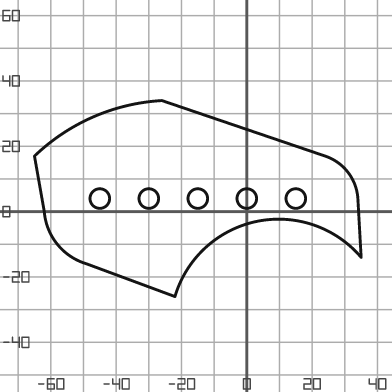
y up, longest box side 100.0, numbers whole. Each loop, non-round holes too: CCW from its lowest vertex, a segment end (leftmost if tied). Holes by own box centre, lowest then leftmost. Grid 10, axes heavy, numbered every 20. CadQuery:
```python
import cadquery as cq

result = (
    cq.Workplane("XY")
    .moveTo(-22.0, -26.0)
    .threePointArc((3.0, -3.0), (35.0, -14.0))
    .lineTo(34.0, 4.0)
    .threePointArc((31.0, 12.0), (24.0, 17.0))
    .lineTo(-26.0, 34.0)
    .threePointArc((-47.0, 29.0), (-65.0, 17.0))
    .lineTo(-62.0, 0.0)
    .threePointArc((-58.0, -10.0), (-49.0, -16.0))
    .close()
    .moveTo(-45.0, 4.0)
    .circle(3.0)
    .moveTo(-30.0, 4.0)
    .circle(3.0)
    .moveTo(-15.0, 4.0)
    .circle(3.0)
    .moveTo(0.0, 4.0)
    .circle(3.0)
    .moveTo(15.0, 4.0)
    .circle(3.0)
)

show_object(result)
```